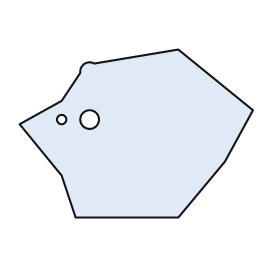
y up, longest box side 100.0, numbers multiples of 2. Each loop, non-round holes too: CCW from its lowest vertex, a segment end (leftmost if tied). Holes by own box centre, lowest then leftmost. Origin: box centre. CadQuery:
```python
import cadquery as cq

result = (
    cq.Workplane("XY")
    .moveTo(-26.0, -36.0)
    .lineTo(18.0, -36.0)
    .lineTo(38.0, -12.0)
    .lineTo(50.0, 10.0)
    .lineTo(18.0, 36.0)
    .lineTo(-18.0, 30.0)
    .threePointArc((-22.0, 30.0), (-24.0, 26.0))
    .lineTo(-32.0, 14.0)
    .lineTo(-50.0, 4.0)
    .lineTo(-32.0, -18.0)
    .close()
    .moveTo(-32.0, 6.0)
    .circle(2.0)
    .moveTo(-20.0, 6.0)
    .circle(4.0)
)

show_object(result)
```